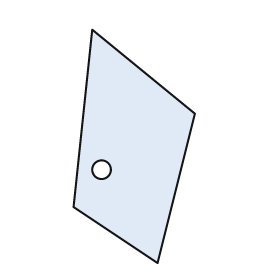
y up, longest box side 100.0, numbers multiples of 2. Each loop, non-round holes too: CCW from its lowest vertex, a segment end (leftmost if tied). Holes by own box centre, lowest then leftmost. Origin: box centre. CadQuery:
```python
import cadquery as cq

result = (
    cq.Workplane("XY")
    .moveTo(10.0, -50.0)
    .lineTo(26.0, 14.0)
    .lineTo(-18.0, 50.0)
    .lineTo(-26.0, -26.0)
    .close()
    .moveTo(-14.0, -10.0)
    .circle(4.0)
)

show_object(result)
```